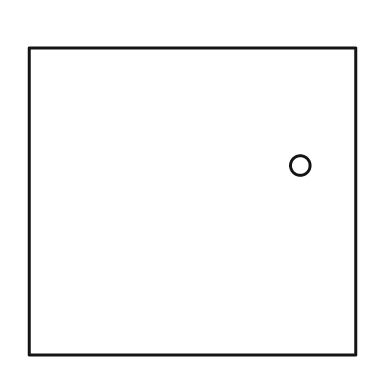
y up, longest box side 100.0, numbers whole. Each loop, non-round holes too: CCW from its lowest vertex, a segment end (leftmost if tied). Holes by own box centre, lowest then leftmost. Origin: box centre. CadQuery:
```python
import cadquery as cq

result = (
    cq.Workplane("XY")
    .moveTo(-50.0, -47.0)
    .lineTo(50.0, -47.0)
    .lineTo(50.0, 47.0)
    .lineTo(-50.0, 47.0)
    .close()
    .moveTo(33.0, 11.0)
    .circle(3.0)
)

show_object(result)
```